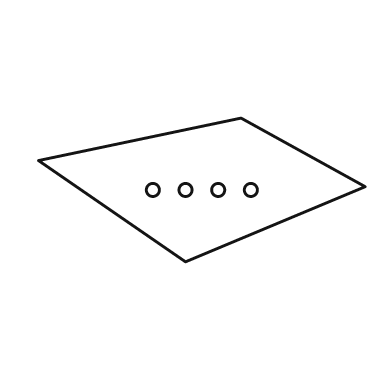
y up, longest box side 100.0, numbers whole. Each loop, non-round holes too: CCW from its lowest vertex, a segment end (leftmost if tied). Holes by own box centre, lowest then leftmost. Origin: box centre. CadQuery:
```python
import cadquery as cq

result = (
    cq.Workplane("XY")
    .moveTo(-5.0, -22.0)
    .lineTo(50.0, 1.0)
    .lineTo(12.0, 22.0)
    .lineTo(-50.0, 9.0)
    .close()
    .moveTo(-15.0, 0.0)
    .circle(2.0)
    .moveTo(-5.0, 0.0)
    .circle(2.0)
    .moveTo(5.0, 0.0)
    .circle(2.0)
    .moveTo(15.0, 0.0)
    .circle(2.0)
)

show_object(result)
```